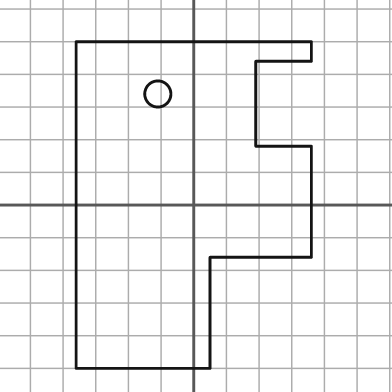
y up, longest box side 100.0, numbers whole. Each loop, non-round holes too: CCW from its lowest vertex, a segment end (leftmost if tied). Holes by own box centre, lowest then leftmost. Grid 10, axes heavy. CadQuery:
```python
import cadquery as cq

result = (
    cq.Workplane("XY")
    .moveTo(-36.0, -50.0)
    .lineTo(5.0, -50.0)
    .lineTo(5.0, -16.0)
    .lineTo(36.0, -16.0)
    .lineTo(36.0, 18.0)
    .lineTo(19.0, 18.0)
    .lineTo(19.0, 44.0)
    .lineTo(36.0, 44.0)
    .lineTo(36.0, 50.0)
    .lineTo(-36.0, 50.0)
    .close()
    .moveTo(-11.0, 34.0)
    .circle(4.0)
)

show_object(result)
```